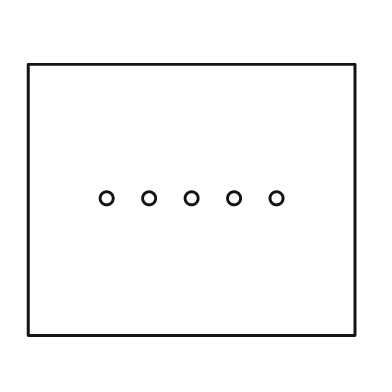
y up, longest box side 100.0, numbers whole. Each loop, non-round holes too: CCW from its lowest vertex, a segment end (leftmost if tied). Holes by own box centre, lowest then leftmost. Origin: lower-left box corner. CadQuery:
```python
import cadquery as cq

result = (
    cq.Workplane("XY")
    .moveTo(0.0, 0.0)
    .lineTo(100.0, 0.0)
    .lineTo(100.0, 83.0)
    .lineTo(0.0, 83.0)
    .close()
    .moveTo(24.0, 42.0)
    .circle(2.0)
    .moveTo(37.0, 42.0)
    .circle(2.0)
    .moveTo(50.0, 42.0)
    .circle(2.0)
    .moveTo(63.0, 42.0)
    .circle(2.0)
    .moveTo(76.0, 42.0)
    .circle(2.0)
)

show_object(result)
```